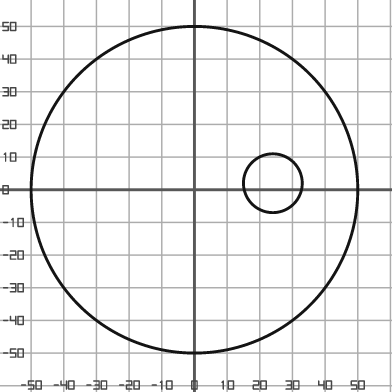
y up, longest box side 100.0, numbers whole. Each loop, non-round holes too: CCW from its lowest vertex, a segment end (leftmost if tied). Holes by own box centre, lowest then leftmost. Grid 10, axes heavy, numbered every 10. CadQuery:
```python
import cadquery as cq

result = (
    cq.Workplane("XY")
    .moveTo(0.0, 0.0)
    .circle(50.0)
    .moveTo(24.0, 2.0)
    .circle(9.0)
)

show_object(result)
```